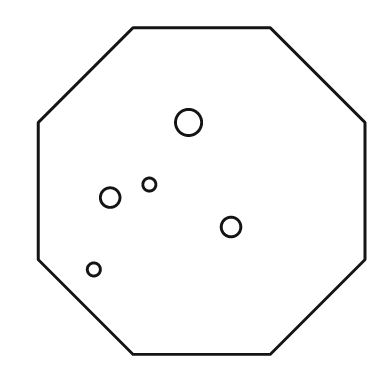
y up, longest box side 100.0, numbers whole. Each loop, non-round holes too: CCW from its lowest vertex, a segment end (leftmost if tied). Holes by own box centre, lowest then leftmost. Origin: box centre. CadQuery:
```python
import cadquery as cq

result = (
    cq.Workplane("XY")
    .moveTo(-21.0, -50.0)
    .lineTo(21.0, -50.0)
    .lineTo(50.0, -21.0)
    .lineTo(50.0, 21.0)
    .lineTo(21.0, 50.0)
    .lineTo(-21.0, 50.0)
    .lineTo(-50.0, 21.0)
    .lineTo(-50.0, -21.0)
    .close()
    .moveTo(-33.0, -24.0)
    .circle(2.0)
    .moveTo(9.0, -11.0)
    .circle(3.0)
    .moveTo(-28.0, -2.0)
    .circle(3.0)
    .moveTo(-16.0, 2.0)
    .circle(2.0)
    .moveTo(-4.0, 21.0)
    .circle(4.0)
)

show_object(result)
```